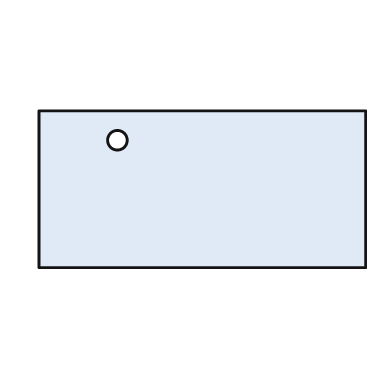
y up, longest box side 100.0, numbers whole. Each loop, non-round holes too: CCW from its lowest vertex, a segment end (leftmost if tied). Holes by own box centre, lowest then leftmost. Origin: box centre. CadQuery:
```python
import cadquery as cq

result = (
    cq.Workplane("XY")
    .moveTo(-50.0, -24.0)
    .lineTo(50.0, -24.0)
    .lineTo(50.0, 24.0)
    .lineTo(-50.0, 24.0)
    .close()
    .moveTo(-26.0, 15.0)
    .circle(3.0)
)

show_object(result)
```